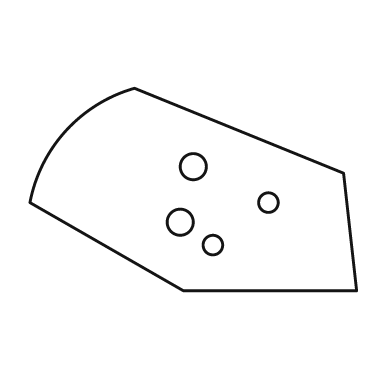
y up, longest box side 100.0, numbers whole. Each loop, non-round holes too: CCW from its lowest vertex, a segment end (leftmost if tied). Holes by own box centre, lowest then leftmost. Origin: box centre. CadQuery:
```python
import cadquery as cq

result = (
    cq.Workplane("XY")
    .moveTo(-3.0, -31.0)
    .lineTo(50.0, -31.0)
    .lineTo(46.0, 5.0)
    .lineTo(-18.0, 31.0)
    .threePointArc((-39.0, 18.0), (-50.0, -4.0))
    .close()
    .moveTo(6.0, -17.0)
    .circle(3.0)
    .moveTo(-4.0, -10.0)
    .circle(4.0)
    .moveTo(23.0, -4.0)
    .circle(3.0)
    .moveTo(0.0, 7.0)
    .circle(4.0)
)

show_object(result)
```